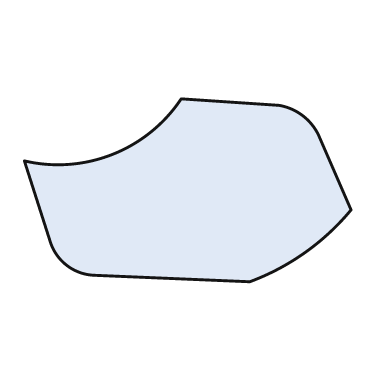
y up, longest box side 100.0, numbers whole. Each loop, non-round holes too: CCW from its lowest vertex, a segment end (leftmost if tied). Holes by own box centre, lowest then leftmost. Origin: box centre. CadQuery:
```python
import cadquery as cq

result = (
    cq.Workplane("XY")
    .moveTo(19.0, -28.0)
    .threePointArc((36.0, -19.0), (50.0, -6.0))
    .lineTo(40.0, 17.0)
    .threePointArc((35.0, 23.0), (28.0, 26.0))
    .lineTo(-2.0, 28.0)
    .threePointArc((-23.0, 11.0), (-50.0, 9.0))
    .lineTo(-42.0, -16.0)
    .threePointArc((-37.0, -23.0), (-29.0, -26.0))
    .close()
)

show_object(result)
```